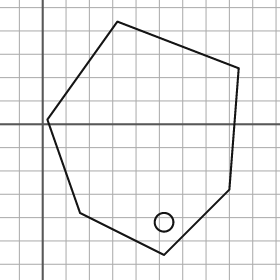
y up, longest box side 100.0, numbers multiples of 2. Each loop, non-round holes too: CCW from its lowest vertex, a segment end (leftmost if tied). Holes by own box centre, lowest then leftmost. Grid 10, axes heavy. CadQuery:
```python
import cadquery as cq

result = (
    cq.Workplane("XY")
    .moveTo(52.0, -56.0)
    .lineTo(80.0, -28.0)
    .lineTo(84.0, 24.0)
    .lineTo(32.0, 44.0)
    .lineTo(2.0, 2.0)
    .lineTo(16.0, -38.0)
    .close()
    .moveTo(52.0, -42.0)
    .circle(4.0)
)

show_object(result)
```